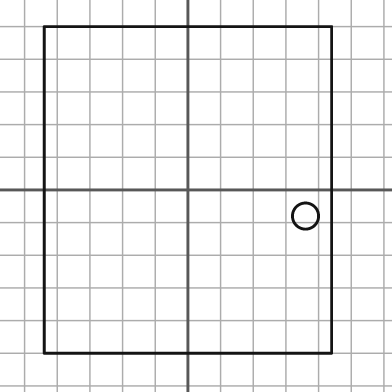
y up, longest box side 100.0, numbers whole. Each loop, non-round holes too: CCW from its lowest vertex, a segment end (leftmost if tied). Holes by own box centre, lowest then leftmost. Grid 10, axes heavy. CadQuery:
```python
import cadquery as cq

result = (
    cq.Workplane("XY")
    .moveTo(-44.0, -50.0)
    .lineTo(44.0, -50.0)
    .lineTo(44.0, 50.0)
    .lineTo(-44.0, 50.0)
    .close()
    .moveTo(36.0, -8.0)
    .circle(4.0)
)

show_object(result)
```